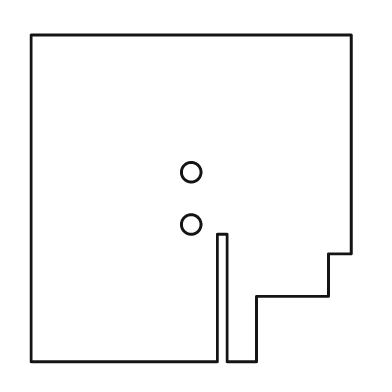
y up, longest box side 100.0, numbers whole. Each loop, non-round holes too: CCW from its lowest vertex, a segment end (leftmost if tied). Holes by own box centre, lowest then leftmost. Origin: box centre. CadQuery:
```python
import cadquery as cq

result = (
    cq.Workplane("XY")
    .moveTo(-49.0, -50.0)
    .lineTo(8.0, -50.0)
    .lineTo(8.0, -11.0)
    .lineTo(11.0, -11.0)
    .lineTo(11.0, -50.0)
    .lineTo(20.0, -50.0)
    .lineTo(20.0, -30.0)
    .lineTo(42.0, -30.0)
    .lineTo(42.0, -17.0)
    .lineTo(49.0, -17.0)
    .lineTo(49.0, 50.0)
    .lineTo(-49.0, 50.0)
    .close()
    .moveTo(0.0, -8.0)
    .circle(3.0)
    .moveTo(0.0, 8.0)
    .circle(3.0)
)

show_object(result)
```